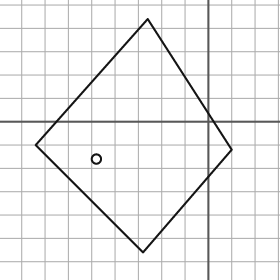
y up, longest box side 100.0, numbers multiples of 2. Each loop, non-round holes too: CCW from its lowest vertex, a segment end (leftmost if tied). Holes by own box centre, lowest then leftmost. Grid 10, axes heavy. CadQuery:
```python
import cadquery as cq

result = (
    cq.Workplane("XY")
    .moveTo(-28.0, -56.0)
    .lineTo(10.0, -12.0)
    .lineTo(-26.0, 44.0)
    .lineTo(-74.0, -10.0)
    .close()
    .moveTo(-48.0, -16.0)
    .circle(2.0)
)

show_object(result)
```